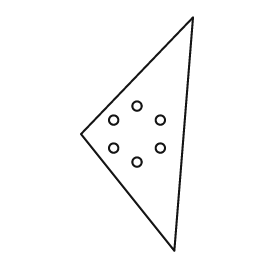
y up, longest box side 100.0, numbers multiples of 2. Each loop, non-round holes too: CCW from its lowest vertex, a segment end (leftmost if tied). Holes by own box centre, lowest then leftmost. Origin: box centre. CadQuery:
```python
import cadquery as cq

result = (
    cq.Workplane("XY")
    .moveTo(16.0, -50.0)
    .lineTo(24.0, 50.0)
    .lineTo(-24.0, 0.0)
    .close()
    .moveTo(0.0, -12.0)
    .circle(2.0)
    .moveTo(-10.0, -6.0)
    .circle(2.0)
    .moveTo(10.0, -6.0)
    .circle(2.0)
    .moveTo(-10.0, 6.0)
    .circle(2.0)
    .moveTo(10.0, 6.0)
    .circle(2.0)
    .moveTo(0.0, 12.0)
    .circle(2.0)
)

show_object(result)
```